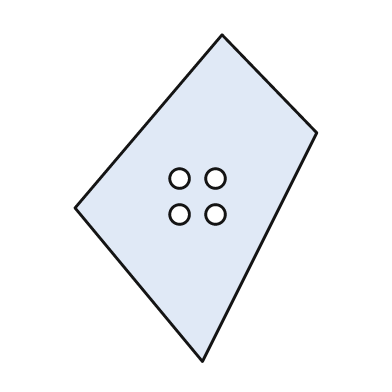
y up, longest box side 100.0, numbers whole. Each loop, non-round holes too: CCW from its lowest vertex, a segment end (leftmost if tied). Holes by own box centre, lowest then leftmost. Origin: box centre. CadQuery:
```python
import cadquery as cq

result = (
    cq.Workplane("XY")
    .moveTo(2.0, -50.0)
    .lineTo(37.0, 20.0)
    .lineTo(8.0, 50.0)
    .lineTo(-37.0, -3.0)
    .close()
    .moveTo(-5.0, -5.0)
    .circle(3.0)
    .moveTo(6.0, -5.0)
    .circle(3.0)
    .moveTo(-5.0, 6.0)
    .circle(3.0)
    .moveTo(6.0, 6.0)
    .circle(3.0)
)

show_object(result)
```